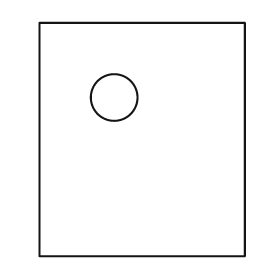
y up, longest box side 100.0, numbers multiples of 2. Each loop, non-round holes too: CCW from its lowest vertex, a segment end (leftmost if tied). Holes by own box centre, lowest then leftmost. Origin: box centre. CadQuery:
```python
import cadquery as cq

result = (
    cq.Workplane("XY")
    .moveTo(-44.0, -50.0)
    .lineTo(44.0, -50.0)
    .lineTo(44.0, 50.0)
    .lineTo(-44.0, 50.0)
    .close()
    .moveTo(-12.0, 18.0)
    .circle(10.0)
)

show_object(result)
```